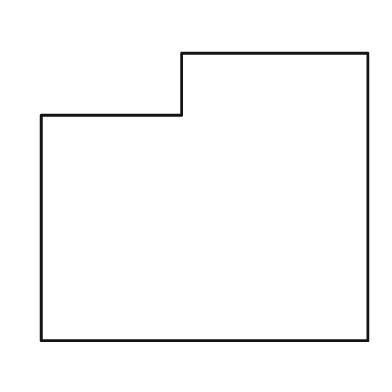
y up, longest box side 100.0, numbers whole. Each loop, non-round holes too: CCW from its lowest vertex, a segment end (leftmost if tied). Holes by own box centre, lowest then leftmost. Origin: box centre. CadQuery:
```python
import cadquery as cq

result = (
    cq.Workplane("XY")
    .moveTo(-50.0, -44.0)
    .lineTo(50.0, -44.0)
    .lineTo(50.0, 44.0)
    .lineTo(-7.0, 44.0)
    .lineTo(-7.0, 25.0)
    .lineTo(-50.0, 25.0)
    .close()
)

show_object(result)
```